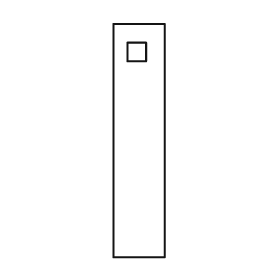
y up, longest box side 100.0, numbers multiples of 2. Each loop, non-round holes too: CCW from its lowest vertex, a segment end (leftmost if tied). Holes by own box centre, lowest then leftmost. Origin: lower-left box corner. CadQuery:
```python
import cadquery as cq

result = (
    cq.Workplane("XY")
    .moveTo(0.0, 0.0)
    .lineTo(22.0, 0.0)
    .lineTo(22.0, 100.0)
    .lineTo(0.0, 100.0)
    .close()
    .moveTo(6.0, 84.0)
    .lineTo(14.0, 84.0)
    .lineTo(14.0, 92.0)
    .lineTo(6.0, 92.0)
    .close()
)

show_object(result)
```